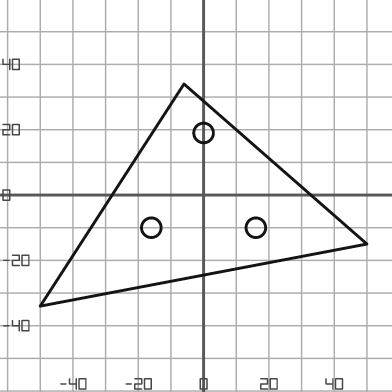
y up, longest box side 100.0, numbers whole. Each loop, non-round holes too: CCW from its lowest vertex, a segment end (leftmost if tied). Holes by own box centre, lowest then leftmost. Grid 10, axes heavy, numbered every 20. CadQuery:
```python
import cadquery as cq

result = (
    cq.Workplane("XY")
    .moveTo(-50.0, -34.0)
    .lineTo(50.0, -15.0)
    .lineTo(-6.0, 34.0)
    .close()
    .moveTo(-16.0, -10.0)
    .circle(3.0)
    .moveTo(16.0, -10.0)
    .circle(3.0)
    .moveTo(0.0, 19.0)
    .circle(3.0)
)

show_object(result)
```